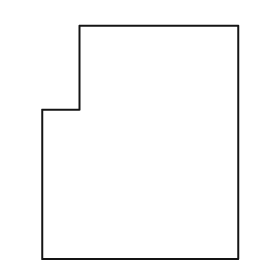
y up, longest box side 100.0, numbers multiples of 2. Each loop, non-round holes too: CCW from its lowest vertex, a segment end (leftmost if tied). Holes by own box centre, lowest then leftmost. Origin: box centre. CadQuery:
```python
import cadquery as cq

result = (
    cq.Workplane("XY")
    .moveTo(-42.0, -50.0)
    .lineTo(42.0, -50.0)
    .lineTo(42.0, 50.0)
    .lineTo(-26.0, 50.0)
    .lineTo(-26.0, 14.0)
    .lineTo(-42.0, 14.0)
    .close()
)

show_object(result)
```